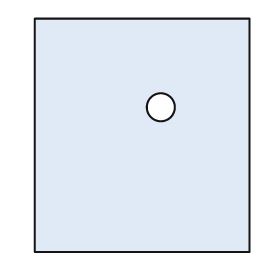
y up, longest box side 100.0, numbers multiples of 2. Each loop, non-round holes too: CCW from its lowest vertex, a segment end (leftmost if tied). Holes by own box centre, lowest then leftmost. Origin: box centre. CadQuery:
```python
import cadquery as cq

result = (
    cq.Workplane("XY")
    .moveTo(-46.0, -50.0)
    .lineTo(46.0, -50.0)
    .lineTo(46.0, 50.0)
    .lineTo(-46.0, 50.0)
    .close()
    .moveTo(8.0, 12.0)
    .circle(6.0)
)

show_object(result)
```